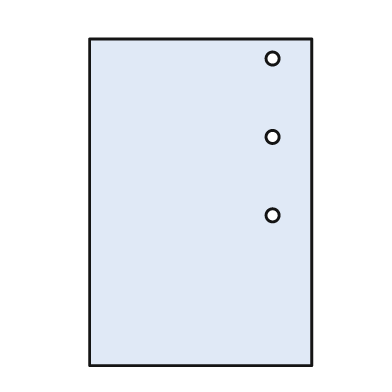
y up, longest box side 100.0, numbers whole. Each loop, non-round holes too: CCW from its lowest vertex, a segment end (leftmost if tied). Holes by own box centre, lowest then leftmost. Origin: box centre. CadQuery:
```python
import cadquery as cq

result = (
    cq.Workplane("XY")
    .moveTo(-34.0, -50.0)
    .lineTo(34.0, -50.0)
    .lineTo(34.0, 50.0)
    .lineTo(-34.0, 50.0)
    .close()
    .moveTo(22.0, -4.0)
    .circle(2.0)
    .moveTo(22.0, 20.0)
    .circle(2.0)
    .moveTo(22.0, 44.0)
    .circle(2.0)
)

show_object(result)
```